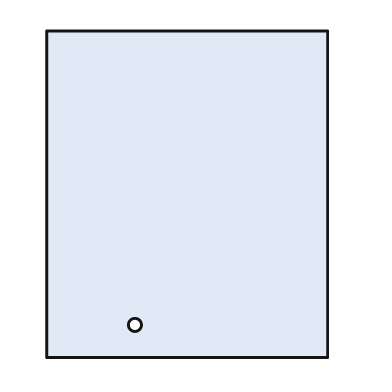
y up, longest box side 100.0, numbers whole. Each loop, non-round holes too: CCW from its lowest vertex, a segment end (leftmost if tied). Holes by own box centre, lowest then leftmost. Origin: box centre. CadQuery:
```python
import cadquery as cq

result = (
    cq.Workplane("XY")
    .moveTo(-43.0, -50.0)
    .lineTo(43.0, -50.0)
    .lineTo(43.0, 50.0)
    .lineTo(-43.0, 50.0)
    .close()
    .moveTo(-16.0, -40.0)
    .circle(2.0)
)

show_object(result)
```